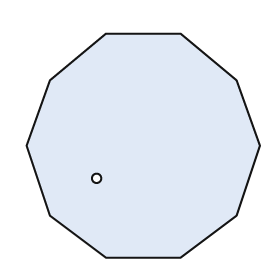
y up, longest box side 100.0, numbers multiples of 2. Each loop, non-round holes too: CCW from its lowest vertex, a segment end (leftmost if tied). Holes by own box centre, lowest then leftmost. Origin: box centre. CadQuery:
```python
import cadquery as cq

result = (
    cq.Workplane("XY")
    .moveTo(-16.0, -48.0)
    .lineTo(16.0, -48.0)
    .lineTo(40.0, -30.0)
    .lineTo(50.0, 0.0)
    .lineTo(40.0, 28.0)
    .lineTo(16.0, 48.0)
    .lineTo(-16.0, 48.0)
    .lineTo(-40.0, 28.0)
    .lineTo(-50.0, 0.0)
    .lineTo(-40.0, -30.0)
    .close()
    .moveTo(-20.0, -14.0)
    .circle(2.0)
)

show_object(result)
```